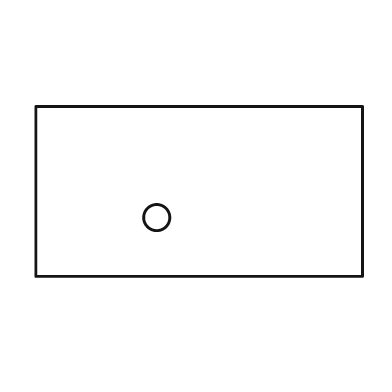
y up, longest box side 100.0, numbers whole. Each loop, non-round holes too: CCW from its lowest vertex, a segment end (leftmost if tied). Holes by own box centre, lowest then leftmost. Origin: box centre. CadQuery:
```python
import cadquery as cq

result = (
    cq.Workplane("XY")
    .moveTo(-50.0, -26.0)
    .lineTo(50.0, -26.0)
    .lineTo(50.0, 26.0)
    .lineTo(-50.0, 26.0)
    .close()
    .moveTo(-13.0, -8.0)
    .circle(4.0)
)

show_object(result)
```